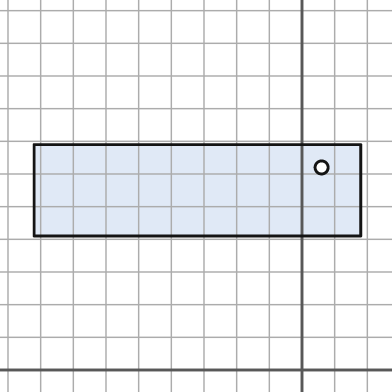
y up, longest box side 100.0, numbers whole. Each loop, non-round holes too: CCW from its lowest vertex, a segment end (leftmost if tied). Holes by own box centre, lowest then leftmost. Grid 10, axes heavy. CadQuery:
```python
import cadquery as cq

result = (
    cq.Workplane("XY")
    .moveTo(-82.0, 41.0)
    .lineTo(18.0, 41.0)
    .lineTo(18.0, 69.0)
    .lineTo(-82.0, 69.0)
    .close()
    .moveTo(6.0, 62.0)
    .circle(2.0)
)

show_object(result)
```